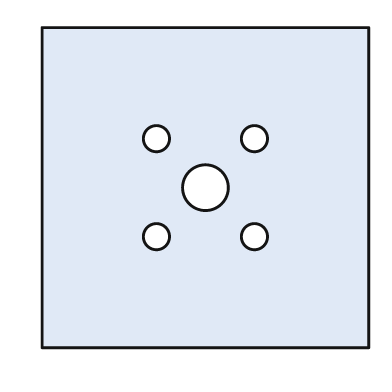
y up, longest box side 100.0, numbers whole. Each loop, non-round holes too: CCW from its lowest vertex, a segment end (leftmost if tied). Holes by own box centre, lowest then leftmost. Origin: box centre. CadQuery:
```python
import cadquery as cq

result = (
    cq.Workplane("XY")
    .moveTo(-50.0, -49.0)
    .lineTo(50.0, -49.0)
    .lineTo(50.0, 49.0)
    .lineTo(-50.0, 49.0)
    .close()
    .moveTo(-15.0, -15.0)
    .circle(4.0)
    .moveTo(15.0, -15.0)
    .circle(4.0)
    .moveTo(0.0, 0.0)
    .circle(7.0)
    .moveTo(-15.0, 15.0)
    .circle(4.0)
    .moveTo(15.0, 15.0)
    .circle(4.0)
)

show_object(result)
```